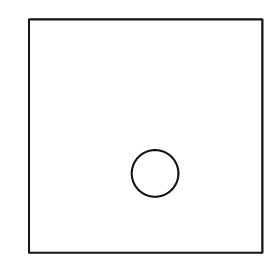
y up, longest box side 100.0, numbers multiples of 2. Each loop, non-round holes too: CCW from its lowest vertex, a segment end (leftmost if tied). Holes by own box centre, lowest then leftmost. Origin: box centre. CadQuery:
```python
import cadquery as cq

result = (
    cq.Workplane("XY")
    .moveTo(-50.0, -50.0)
    .lineTo(50.0, -50.0)
    .lineTo(50.0, 50.0)
    .lineTo(-50.0, 50.0)
    .close()
    .moveTo(4.0, -16.0)
    .circle(10.0)
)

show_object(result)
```